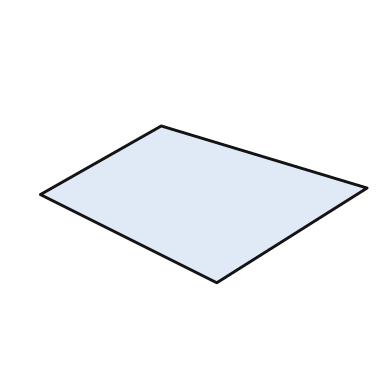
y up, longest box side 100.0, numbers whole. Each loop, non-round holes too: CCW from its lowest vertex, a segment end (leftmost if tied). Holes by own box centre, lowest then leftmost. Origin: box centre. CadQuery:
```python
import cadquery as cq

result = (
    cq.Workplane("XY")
    .moveTo(4.0, -24.0)
    .lineTo(50.0, 5.0)
    .lineTo(-13.0, 24.0)
    .lineTo(-50.0, 3.0)
    .close()
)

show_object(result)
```